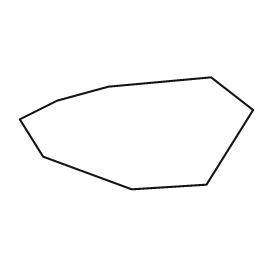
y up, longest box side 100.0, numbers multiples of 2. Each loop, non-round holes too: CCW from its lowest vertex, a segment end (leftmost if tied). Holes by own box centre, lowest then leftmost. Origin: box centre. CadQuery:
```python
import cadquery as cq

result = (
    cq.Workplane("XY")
    .moveTo(-2.0, -24.0)
    .lineTo(30.0, -22.0)
    .lineTo(50.0, 10.0)
    .lineTo(32.0, 24.0)
    .lineTo(-12.0, 20.0)
    .lineTo(-34.0, 14.0)
    .lineTo(-50.0, 6.0)
    .lineTo(-40.0, -10.0)
    .close()
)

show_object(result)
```